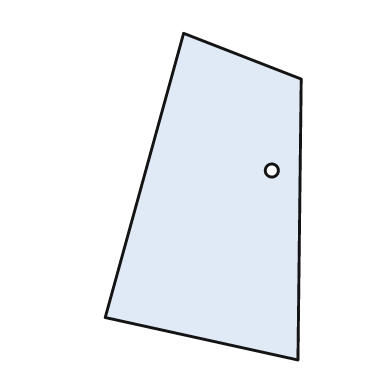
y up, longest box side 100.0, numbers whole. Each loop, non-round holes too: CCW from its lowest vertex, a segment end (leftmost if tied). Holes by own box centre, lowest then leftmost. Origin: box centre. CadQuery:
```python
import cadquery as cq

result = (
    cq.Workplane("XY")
    .moveTo(29.0, -50.0)
    .lineTo(30.0, 36.0)
    .lineTo(-6.0, 50.0)
    .lineTo(-30.0, -37.0)
    .close()
    .moveTo(21.0, 8.0)
    .circle(2.0)
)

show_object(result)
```